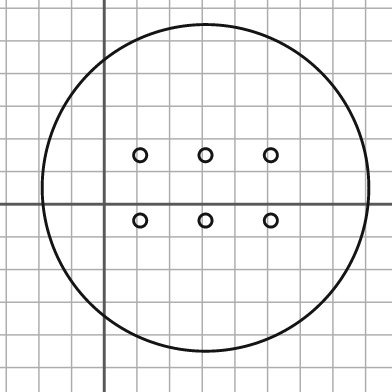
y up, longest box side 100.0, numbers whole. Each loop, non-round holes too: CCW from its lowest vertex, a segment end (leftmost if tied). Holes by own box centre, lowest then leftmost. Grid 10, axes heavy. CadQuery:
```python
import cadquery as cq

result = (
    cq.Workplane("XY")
    .moveTo(31.0, 5.0)
    .circle(50.0)
    .moveTo(11.0, -5.0)
    .circle(2.0)
    .moveTo(31.0, -5.0)
    .circle(2.0)
    .moveTo(51.0, -5.0)
    .circle(2.0)
    .moveTo(11.0, 15.0)
    .circle(2.0)
    .moveTo(31.0, 15.0)
    .circle(2.0)
    .moveTo(51.0, 15.0)
    .circle(2.0)
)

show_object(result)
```